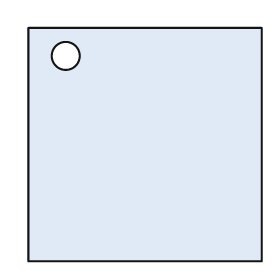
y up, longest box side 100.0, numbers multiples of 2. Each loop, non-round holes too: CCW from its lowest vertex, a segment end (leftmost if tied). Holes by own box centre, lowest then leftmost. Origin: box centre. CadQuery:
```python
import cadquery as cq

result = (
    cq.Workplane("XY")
    .moveTo(-50.0, -50.0)
    .lineTo(50.0, -50.0)
    .lineTo(50.0, 50.0)
    .lineTo(-50.0, 50.0)
    .close()
    .moveTo(-34.0, 38.0)
    .circle(6.0)
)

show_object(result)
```